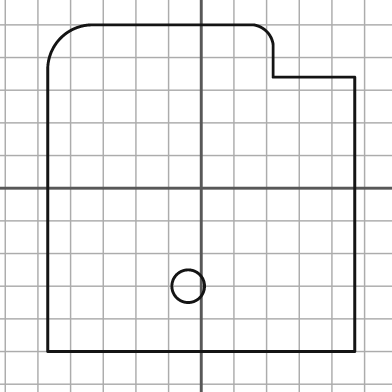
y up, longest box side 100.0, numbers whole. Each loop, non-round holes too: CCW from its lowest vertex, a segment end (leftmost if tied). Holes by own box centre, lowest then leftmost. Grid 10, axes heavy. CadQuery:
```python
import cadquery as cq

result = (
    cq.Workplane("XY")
    .moveTo(-47.0, -50.0)
    .lineTo(47.0, -50.0)
    .lineTo(47.0, 34.0)
    .lineTo(22.0, 34.0)
    .lineTo(22.0, 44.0)
    .threePointArc((20.0, 48.0), (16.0, 50.0))
    .lineTo(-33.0, 50.0)
    .threePointArc((-43.0, 46.0), (-47.0, 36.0))
    .close()
    .moveTo(-4.0, -30.0)
    .circle(5.0)
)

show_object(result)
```